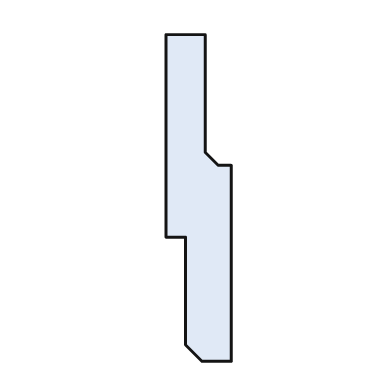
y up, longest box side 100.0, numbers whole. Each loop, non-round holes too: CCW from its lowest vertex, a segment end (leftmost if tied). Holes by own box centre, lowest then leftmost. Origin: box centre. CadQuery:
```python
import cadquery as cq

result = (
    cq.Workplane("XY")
    .moveTo(1.0, -50.0)
    .lineTo(10.0, -50.0)
    .lineTo(10.0, 10.0)
    .lineTo(6.0, 10.0)
    .lineTo(2.0, 14.0)
    .lineTo(2.0, 50.0)
    .lineTo(-10.0, 50.0)
    .lineTo(-10.0, -12.0)
    .lineTo(-4.0, -12.0)
    .lineTo(-4.0, -45.0)
    .close()
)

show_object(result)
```